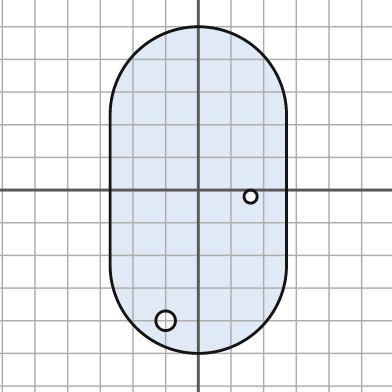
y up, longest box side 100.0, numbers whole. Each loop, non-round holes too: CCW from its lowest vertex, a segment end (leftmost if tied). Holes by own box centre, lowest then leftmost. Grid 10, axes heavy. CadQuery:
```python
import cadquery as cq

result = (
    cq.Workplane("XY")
    .moveTo(-27.0, -23.0)
    .threePointArc((0.0, -50.0), (27.0, -23.0))
    .lineTo(27.0, 23.0)
    .threePointArc((0.0, 50.0), (-27.0, 23.0))
    .close()
    .moveTo(-10.0, -40.0)
    .circle(3.0)
    .moveTo(16.0, -2.0)
    .circle(2.0)
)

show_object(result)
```